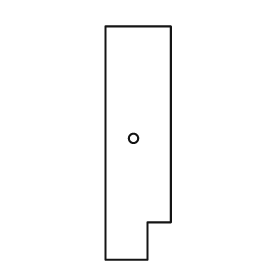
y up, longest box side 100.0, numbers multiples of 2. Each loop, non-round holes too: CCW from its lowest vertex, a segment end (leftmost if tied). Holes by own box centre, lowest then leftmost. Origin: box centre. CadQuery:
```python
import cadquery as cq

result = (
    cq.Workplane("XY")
    .moveTo(-14.0, -50.0)
    .lineTo(4.0, -50.0)
    .lineTo(4.0, -34.0)
    .lineTo(14.0, -34.0)
    .lineTo(14.0, 50.0)
    .lineTo(-14.0, 50.0)
    .close()
    .moveTo(-2.0, 2.0)
    .circle(2.0)
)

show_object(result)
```